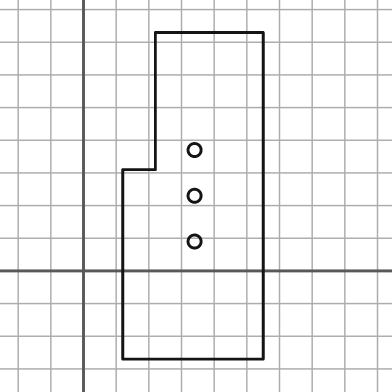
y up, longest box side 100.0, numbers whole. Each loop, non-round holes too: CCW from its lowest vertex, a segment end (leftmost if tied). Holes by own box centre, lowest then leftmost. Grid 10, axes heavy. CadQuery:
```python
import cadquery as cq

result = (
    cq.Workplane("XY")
    .moveTo(12.0, -27.0)
    .lineTo(55.0, -27.0)
    .lineTo(55.0, 73.0)
    .lineTo(22.0, 73.0)
    .lineTo(22.0, 31.0)
    .lineTo(12.0, 31.0)
    .close()
    .moveTo(34.0, 9.0)
    .circle(2.0)
    .moveTo(34.0, 23.0)
    .circle(2.0)
    .moveTo(34.0, 37.0)
    .circle(2.0)
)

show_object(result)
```